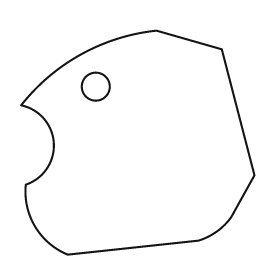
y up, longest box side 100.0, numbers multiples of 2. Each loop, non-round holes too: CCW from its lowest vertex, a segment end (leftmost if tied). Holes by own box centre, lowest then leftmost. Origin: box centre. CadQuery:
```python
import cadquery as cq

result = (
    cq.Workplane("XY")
    .moveTo(-30.0, -48.0)
    .lineTo(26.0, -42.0)
    .threePointArc((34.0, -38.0), (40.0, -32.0))
    .lineTo(50.0, -14.0)
    .lineTo(36.0, 40.0)
    .lineTo(8.0, 48.0)
    .threePointArc((-24.0, 38.0), (-50.0, 16.0))
    .threePointArc((-36.0, 0.0), (-48.0, -18.0))
    .threePointArc((-44.0, -36.0), (-30.0, -48.0))
    .close()
    .moveTo(-18.0, 24.0)
    .circle(6.0)
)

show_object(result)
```